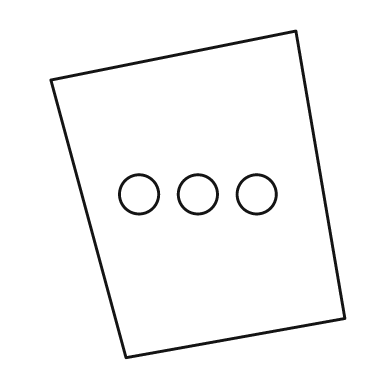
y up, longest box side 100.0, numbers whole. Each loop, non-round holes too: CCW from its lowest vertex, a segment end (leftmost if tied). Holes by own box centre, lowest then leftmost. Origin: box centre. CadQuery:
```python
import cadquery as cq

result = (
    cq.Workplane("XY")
    .moveTo(-22.0, -50.0)
    .lineTo(45.0, -38.0)
    .lineTo(30.0, 50.0)
    .lineTo(-45.0, 35.0)
    .close()
    .moveTo(-18.0, 0.0)
    .circle(6.0)
    .moveTo(0.0, 0.0)
    .circle(6.0)
    .moveTo(18.0, 0.0)
    .circle(6.0)
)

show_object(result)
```